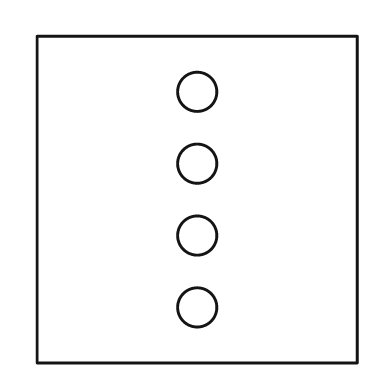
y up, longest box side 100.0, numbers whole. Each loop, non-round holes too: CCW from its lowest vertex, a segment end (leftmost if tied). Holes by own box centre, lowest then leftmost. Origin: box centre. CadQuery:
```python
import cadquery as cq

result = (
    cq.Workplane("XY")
    .moveTo(-49.0, -50.0)
    .lineTo(49.0, -50.0)
    .lineTo(49.0, 50.0)
    .lineTo(-49.0, 50.0)
    .close()
    .moveTo(0.0, -33.0)
    .circle(6.0)
    .moveTo(0.0, -11.0)
    .circle(6.0)
    .moveTo(0.0, 11.0)
    .circle(6.0)
    .moveTo(0.0, 33.0)
    .circle(6.0)
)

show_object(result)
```